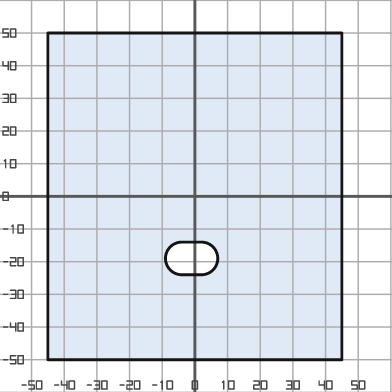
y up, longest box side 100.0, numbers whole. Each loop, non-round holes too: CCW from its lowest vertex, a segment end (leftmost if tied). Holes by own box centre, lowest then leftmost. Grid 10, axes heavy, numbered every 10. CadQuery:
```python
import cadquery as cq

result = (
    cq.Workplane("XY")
    .moveTo(-45.0, -50.0)
    .lineTo(45.0, -50.0)
    .lineTo(45.0, 50.0)
    .lineTo(-45.0, 50.0)
    .close()
    .moveTo(-4.0, -24.0)
    .lineTo(2.0, -24.0)
    .threePointArc((7.0, -19.0), (2.0, -14.0))
    .lineTo(-4.0, -14.0)
    .threePointArc((-9.0, -19.0), (-4.0, -24.0))
    .close()
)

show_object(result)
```